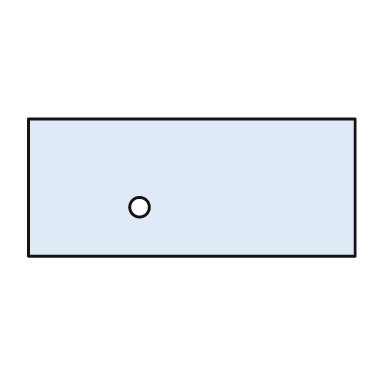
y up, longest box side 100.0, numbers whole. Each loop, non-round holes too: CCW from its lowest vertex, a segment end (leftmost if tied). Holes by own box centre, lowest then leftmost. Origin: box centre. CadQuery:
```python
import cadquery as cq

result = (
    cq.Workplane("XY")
    .moveTo(-50.0, -21.0)
    .lineTo(50.0, -21.0)
    .lineTo(50.0, 21.0)
    .lineTo(-50.0, 21.0)
    .close()
    .moveTo(-16.0, -6.0)
    .circle(3.0)
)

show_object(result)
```